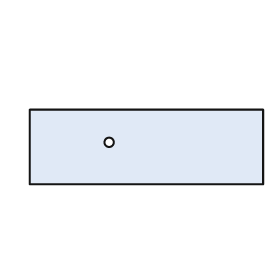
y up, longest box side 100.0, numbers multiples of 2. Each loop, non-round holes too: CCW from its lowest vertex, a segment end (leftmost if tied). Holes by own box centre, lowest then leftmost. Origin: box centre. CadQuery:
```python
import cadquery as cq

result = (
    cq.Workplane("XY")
    .moveTo(-50.0, -16.0)
    .lineTo(50.0, -16.0)
    .lineTo(50.0, 16.0)
    .lineTo(-50.0, 16.0)
    .close()
    .moveTo(-16.0, 2.0)
    .circle(2.0)
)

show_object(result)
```